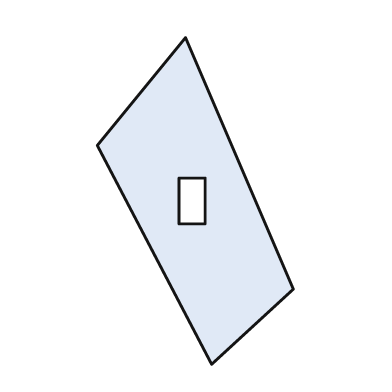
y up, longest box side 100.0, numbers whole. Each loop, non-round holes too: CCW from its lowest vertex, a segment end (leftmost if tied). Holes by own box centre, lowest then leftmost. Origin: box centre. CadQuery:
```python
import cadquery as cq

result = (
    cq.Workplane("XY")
    .moveTo(5.0, -50.0)
    .lineTo(30.0, -27.0)
    .lineTo(-3.0, 50.0)
    .lineTo(-30.0, 17.0)
    .close()
    .moveTo(-5.0, -7.0)
    .lineTo(3.0, -7.0)
    .lineTo(3.0, 7.0)
    .lineTo(-5.0, 7.0)
    .close()
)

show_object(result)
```